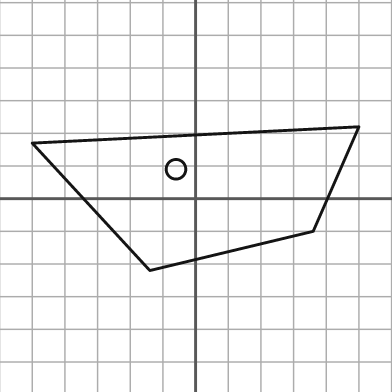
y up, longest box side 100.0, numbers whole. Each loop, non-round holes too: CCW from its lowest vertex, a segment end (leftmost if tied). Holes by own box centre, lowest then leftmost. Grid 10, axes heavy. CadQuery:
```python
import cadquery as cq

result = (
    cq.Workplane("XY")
    .moveTo(-14.0, -22.0)
    .lineTo(36.0, -10.0)
    .lineTo(50.0, 22.0)
    .lineTo(-50.0, 17.0)
    .close()
    .moveTo(-6.0, 9.0)
    .circle(3.0)
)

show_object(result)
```